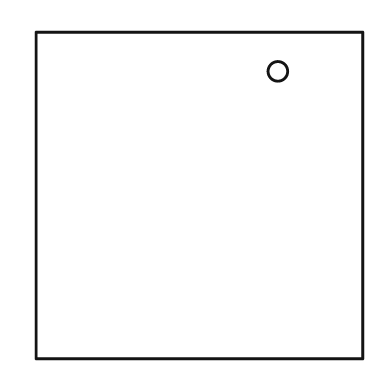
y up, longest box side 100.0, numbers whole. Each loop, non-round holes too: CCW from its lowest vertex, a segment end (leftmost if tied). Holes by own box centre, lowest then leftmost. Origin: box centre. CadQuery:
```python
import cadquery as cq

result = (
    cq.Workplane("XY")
    .moveTo(-50.0, -50.0)
    .lineTo(50.0, -50.0)
    .lineTo(50.0, 50.0)
    .lineTo(-50.0, 50.0)
    .close()
    .moveTo(24.0, 38.0)
    .circle(3.0)
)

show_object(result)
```